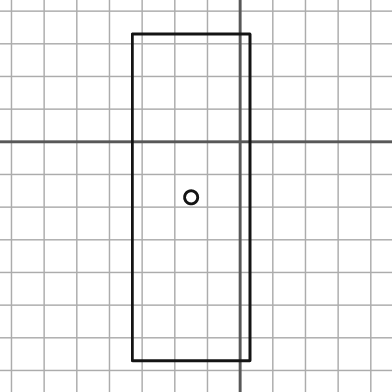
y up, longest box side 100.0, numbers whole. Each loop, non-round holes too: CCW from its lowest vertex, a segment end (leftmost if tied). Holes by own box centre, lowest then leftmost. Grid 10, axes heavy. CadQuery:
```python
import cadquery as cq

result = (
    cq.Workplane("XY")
    .moveTo(-33.0, -67.0)
    .lineTo(3.0, -67.0)
    .lineTo(3.0, 33.0)
    .lineTo(-33.0, 33.0)
    .close()
    .moveTo(-15.0, -17.0)
    .circle(2.0)
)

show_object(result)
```